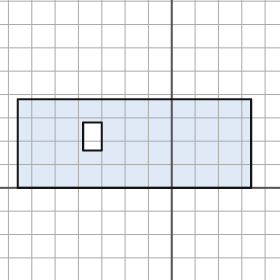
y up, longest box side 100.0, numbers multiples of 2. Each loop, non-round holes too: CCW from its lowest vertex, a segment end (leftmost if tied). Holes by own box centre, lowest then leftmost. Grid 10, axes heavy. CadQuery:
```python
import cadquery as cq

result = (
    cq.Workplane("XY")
    .moveTo(-66.0, 0.0)
    .lineTo(34.0, 0.0)
    .lineTo(34.0, 38.0)
    .lineTo(-66.0, 38.0)
    .close()
    .moveTo(-38.0, 16.0)
    .lineTo(-30.0, 16.0)
    .lineTo(-30.0, 28.0)
    .lineTo(-38.0, 28.0)
    .close()
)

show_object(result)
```